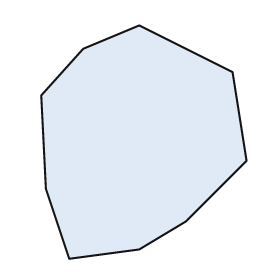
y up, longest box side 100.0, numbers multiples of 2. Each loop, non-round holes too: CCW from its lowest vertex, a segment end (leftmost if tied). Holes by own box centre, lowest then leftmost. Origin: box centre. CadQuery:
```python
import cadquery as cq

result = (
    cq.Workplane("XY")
    .moveTo(-32.0, -50.0)
    .lineTo(-2.0, -46.0)
    .lineTo(18.0, -34.0)
    .lineTo(44.0, -8.0)
    .lineTo(38.0, 30.0)
    .lineTo(-2.0, 50.0)
    .lineTo(-26.0, 40.0)
    .lineTo(-44.0, 20.0)
    .lineTo(-42.0, -20.0)
    .close()
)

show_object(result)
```